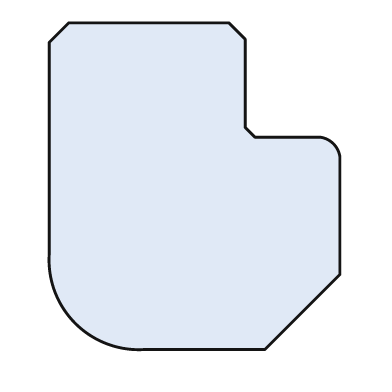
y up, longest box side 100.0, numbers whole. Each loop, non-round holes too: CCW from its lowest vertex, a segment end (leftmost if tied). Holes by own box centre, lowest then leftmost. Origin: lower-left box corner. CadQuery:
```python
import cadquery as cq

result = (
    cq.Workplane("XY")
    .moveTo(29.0, 0.0)
    .lineTo(66.0, 0.0)
    .lineTo(89.0, 23.0)
    .lineTo(89.0, 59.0)
    .threePointArc((87.0, 63.0), (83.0, 65.0))
    .lineTo(63.0, 65.0)
    .lineTo(60.0, 68.0)
    .lineTo(60.0, 95.0)
    .lineTo(55.0, 100.0)
    .lineTo(6.0, 100.0)
    .lineTo(0.0, 94.0)
    .lineTo(0.0, 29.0)
    .threePointArc((8.0, 8.0), (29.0, 0.0))
    .close()
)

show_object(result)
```